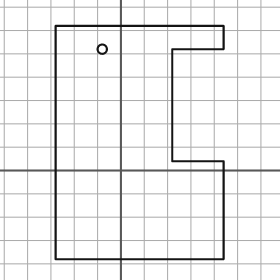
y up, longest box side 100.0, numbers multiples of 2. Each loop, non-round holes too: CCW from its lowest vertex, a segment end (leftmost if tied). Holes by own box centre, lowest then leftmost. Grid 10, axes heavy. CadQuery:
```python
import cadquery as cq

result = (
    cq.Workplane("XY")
    .moveTo(-28.0, -38.0)
    .lineTo(44.0, -38.0)
    .lineTo(44.0, 4.0)
    .lineTo(22.0, 4.0)
    .lineTo(22.0, 52.0)
    .lineTo(44.0, 52.0)
    .lineTo(44.0, 62.0)
    .lineTo(-28.0, 62.0)
    .close()
    .moveTo(-8.0, 52.0)
    .circle(2.0)
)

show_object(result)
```